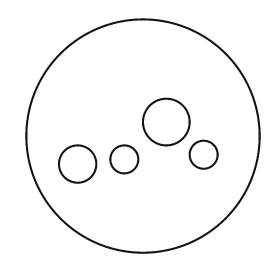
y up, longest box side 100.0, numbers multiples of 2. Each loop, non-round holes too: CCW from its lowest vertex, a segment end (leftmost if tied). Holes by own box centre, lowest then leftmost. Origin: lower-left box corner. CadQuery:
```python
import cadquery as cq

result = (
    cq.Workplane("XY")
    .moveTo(50.0, 50.0)
    .circle(50.0)
    .moveTo(22.0, 38.0)
    .circle(8.0)
    .moveTo(42.0, 40.0)
    .circle(6.0)
    .moveTo(76.0, 42.0)
    .circle(6.0)
    .moveTo(60.0, 56.0)
    .circle(10.0)
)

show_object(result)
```